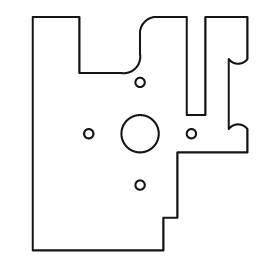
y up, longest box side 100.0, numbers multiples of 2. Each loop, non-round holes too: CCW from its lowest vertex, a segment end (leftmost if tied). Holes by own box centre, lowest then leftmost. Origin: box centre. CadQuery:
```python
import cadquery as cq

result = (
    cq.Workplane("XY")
    .moveTo(-46.0, -50.0)
    .lineTo(10.0, -50.0)
    .lineTo(10.0, -36.0)
    .lineTo(16.0, -36.0)
    .lineTo(16.0, -8.0)
    .lineTo(46.0, -8.0)
    .lineTo(46.0, 2.0)
    .threePointArc((42.0, 4.0), (38.0, 2.0))
    .lineTo(38.0, 32.0)
    .threePointArc((42.0, 30.0), (46.0, 32.0))
    .lineTo(46.0, 50.0)
    .lineTo(28.0, 50.0)
    .lineTo(28.0, 8.0)
    .lineTo(20.0, 8.0)
    .lineTo(20.0, 50.0)
    .lineTo(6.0, 50.0)
    .threePointArc((2.0, 48.0), (0.0, 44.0))
    .lineTo(0.0, 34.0)
    .threePointArc((-2.0, 28.0), (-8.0, 26.0))
    .lineTo(-26.0, 26.0)
    .lineTo(-26.0, 50.0)
    .lineTo(-46.0, 50.0)
    .close()
    .moveTo(0.0, -22.0)
    .circle(2.0)
    .moveTo(-22.0, 0.0)
    .circle(2.0)
    .moveTo(0.0, 0.0)
    .circle(8.0)
    .moveTo(22.0, 0.0)
    .circle(2.0)
    .moveTo(0.0, 22.0)
    .circle(2.0)
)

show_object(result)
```